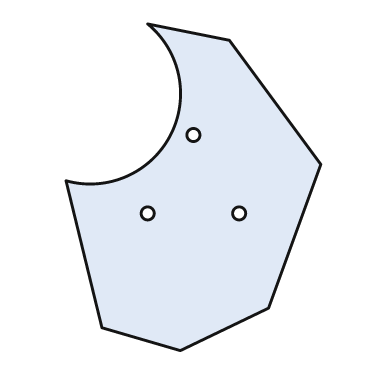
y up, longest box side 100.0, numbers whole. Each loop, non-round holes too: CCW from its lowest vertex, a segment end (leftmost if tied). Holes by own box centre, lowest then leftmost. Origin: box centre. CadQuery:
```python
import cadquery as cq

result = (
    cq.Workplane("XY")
    .moveTo(-4.0, -50.0)
    .lineTo(23.0, -37.0)
    .lineTo(39.0, 7.0)
    .lineTo(11.0, 45.0)
    .lineTo(-14.0, 50.0)
    .threePointArc((-7.0, 16.0), (-39.0, 2.0))
    .lineTo(-28.0, -43.0)
    .close()
    .moveTo(-14.0, -8.0)
    .circle(2.0)
    .moveTo(14.0, -8.0)
    .circle(2.0)
    .moveTo(0.0, 16.0)
    .circle(2.0)
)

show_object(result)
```